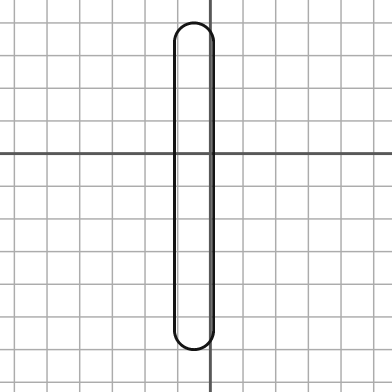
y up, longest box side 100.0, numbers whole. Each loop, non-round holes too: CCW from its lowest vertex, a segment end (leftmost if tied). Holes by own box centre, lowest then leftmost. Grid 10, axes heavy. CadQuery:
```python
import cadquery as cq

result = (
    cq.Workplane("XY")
    .moveTo(-11.0, -54.0)
    .threePointArc((-5.0, -60.0), (1.0, -54.0))
    .lineTo(1.0, 34.0)
    .threePointArc((-5.0, 40.0), (-11.0, 34.0))
    .close()
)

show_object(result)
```